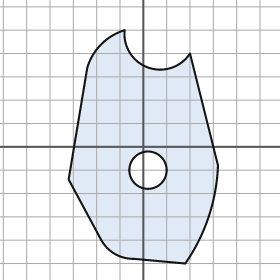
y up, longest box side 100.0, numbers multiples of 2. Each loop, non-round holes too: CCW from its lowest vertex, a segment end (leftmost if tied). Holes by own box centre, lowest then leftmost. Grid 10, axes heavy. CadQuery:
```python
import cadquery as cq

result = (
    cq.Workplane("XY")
    .moveTo(18.0, -50.0)
    .threePointArc((28.0, -30.0), (32.0, -8.0))
    .lineTo(20.0, 40.0)
    .threePointArc((2.0, 34.0), (-8.0, 50.0))
    .threePointArc((-18.0, 44.0), (-24.0, 34.0))
    .lineTo(-32.0, -14.0)
    .lineTo(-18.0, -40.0)
    .threePointArc((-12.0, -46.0), (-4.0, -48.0))
    .close()
    .moveTo(2.0, -10.0)
    .circle(8.0)
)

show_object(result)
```